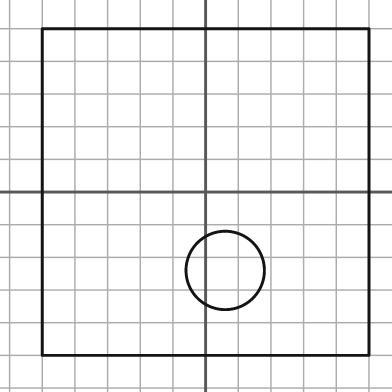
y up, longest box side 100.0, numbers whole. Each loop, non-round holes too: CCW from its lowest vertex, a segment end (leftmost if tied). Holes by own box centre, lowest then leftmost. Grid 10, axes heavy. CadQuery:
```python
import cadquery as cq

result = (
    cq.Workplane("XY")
    .moveTo(-50.0, -50.0)
    .lineTo(50.0, -50.0)
    .lineTo(50.0, 50.0)
    .lineTo(-50.0, 50.0)
    .close()
    .moveTo(6.0, -24.0)
    .circle(12.0)
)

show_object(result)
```